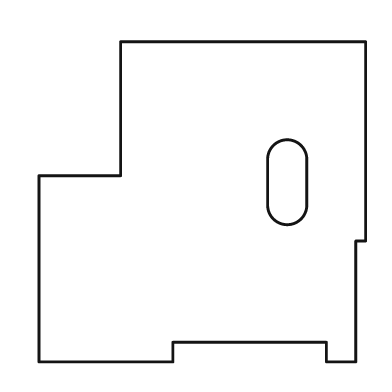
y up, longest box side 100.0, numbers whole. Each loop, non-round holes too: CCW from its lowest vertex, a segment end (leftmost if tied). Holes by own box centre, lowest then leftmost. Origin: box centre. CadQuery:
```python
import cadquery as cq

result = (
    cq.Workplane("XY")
    .moveTo(-50.0, -49.0)
    .lineTo(-9.0, -49.0)
    .lineTo(-9.0, -43.0)
    .lineTo(38.0, -43.0)
    .lineTo(38.0, -49.0)
    .lineTo(47.0, -49.0)
    .lineTo(47.0, -12.0)
    .lineTo(50.0, -12.0)
    .lineTo(50.0, 49.0)
    .lineTo(-25.0, 49.0)
    .lineTo(-25.0, 8.0)
    .lineTo(-50.0, 8.0)
    .close()
    .moveTo(20.0, -1.0)
    .threePointArc((26.0, -7.0), (32.0, -1.0))
    .lineTo(32.0, 13.0)
    .threePointArc((26.0, 19.0), (20.0, 13.0))
    .close()
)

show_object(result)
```